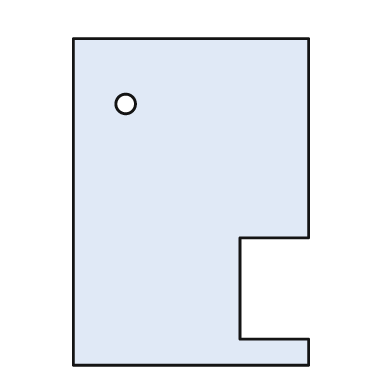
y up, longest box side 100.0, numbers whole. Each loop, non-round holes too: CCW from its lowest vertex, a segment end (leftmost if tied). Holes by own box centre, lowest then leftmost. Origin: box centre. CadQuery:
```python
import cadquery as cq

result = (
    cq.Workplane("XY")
    .moveTo(-36.0, -50.0)
    .lineTo(36.0, -50.0)
    .lineTo(36.0, -42.0)
    .lineTo(15.0, -42.0)
    .lineTo(15.0, -11.0)
    .lineTo(36.0, -11.0)
    .lineTo(36.0, 50.0)
    .lineTo(-36.0, 50.0)
    .close()
    .moveTo(-20.0, 30.0)
    .circle(3.0)
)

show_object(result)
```